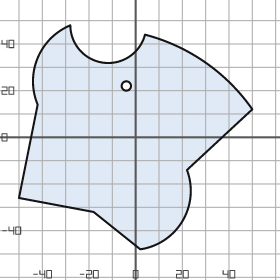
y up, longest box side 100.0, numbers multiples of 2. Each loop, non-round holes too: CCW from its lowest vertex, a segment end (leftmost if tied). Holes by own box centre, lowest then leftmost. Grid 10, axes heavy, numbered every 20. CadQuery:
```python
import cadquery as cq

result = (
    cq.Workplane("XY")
    .moveTo(2.0, -48.0)
    .threePointArc((20.0, -36.0), (22.0, -14.0))
    .lineTo(50.0, 12.0)
    .threePointArc((30.0, 32.0), (4.0, 44.0))
    .threePointArc((-14.0, 32.0), (-28.0, 48.0))
    .threePointArc((-42.0, 34.0), (-42.0, 14.0))
    .lineTo(-50.0, -26.0)
    .lineTo(-18.0, -32.0)
    .close()
    .moveTo(-4.0, 22.0)
    .circle(2.0)
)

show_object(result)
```